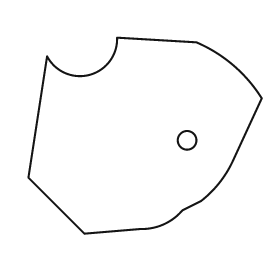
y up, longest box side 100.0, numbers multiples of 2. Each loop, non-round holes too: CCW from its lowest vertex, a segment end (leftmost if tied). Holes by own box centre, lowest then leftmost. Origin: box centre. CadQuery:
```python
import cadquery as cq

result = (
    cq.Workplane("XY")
    .moveTo(-26.0, -42.0)
    .lineTo(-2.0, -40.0)
    .threePointArc((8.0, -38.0), (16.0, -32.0))
    .lineTo(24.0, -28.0)
    .threePointArc((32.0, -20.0), (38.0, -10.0))
    .lineTo(50.0, 16.0)
    .threePointArc((38.0, 30.0), (22.0, 40.0))
    .lineTo(-12.0, 42.0)
    .threePointArc((-24.0, 26.0), (-42.0, 34.0))
    .lineTo(-50.0, -18.0)
    .close()
    .moveTo(18.0, -2.0)
    .circle(4.0)
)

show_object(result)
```